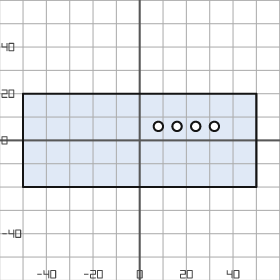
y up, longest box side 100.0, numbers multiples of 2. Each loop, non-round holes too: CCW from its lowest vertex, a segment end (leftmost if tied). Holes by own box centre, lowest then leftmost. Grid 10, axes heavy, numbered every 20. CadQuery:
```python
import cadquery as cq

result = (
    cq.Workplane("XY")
    .moveTo(-50.0, -20.0)
    .lineTo(50.0, -20.0)
    .lineTo(50.0, 20.0)
    .lineTo(-50.0, 20.0)
    .close()
    .moveTo(8.0, 6.0)
    .circle(2.0)
    .moveTo(16.0, 6.0)
    .circle(2.0)
    .moveTo(24.0, 6.0)
    .circle(2.0)
    .moveTo(32.0, 6.0)
    .circle(2.0)
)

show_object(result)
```